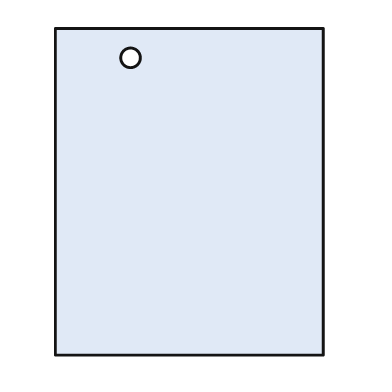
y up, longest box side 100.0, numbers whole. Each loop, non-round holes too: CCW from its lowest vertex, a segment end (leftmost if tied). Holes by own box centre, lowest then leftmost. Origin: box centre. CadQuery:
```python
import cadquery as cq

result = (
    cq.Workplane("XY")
    .moveTo(-41.0, -50.0)
    .lineTo(41.0, -50.0)
    .lineTo(41.0, 50.0)
    .lineTo(-41.0, 50.0)
    .close()
    .moveTo(-18.0, 41.0)
    .circle(3.0)
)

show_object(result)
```